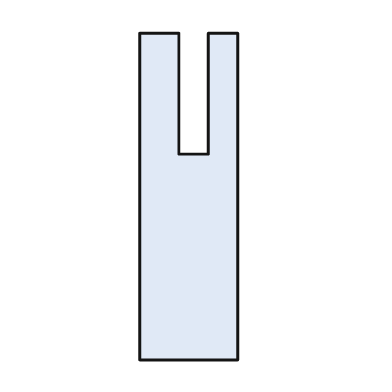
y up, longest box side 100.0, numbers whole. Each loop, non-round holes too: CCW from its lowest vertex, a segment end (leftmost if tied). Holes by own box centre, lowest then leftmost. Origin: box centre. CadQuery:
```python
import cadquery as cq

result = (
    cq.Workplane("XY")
    .moveTo(-15.0, -50.0)
    .lineTo(15.0, -50.0)
    .lineTo(15.0, 50.0)
    .lineTo(6.0, 50.0)
    .lineTo(6.0, 13.0)
    .lineTo(-3.0, 13.0)
    .lineTo(-3.0, 50.0)
    .lineTo(-15.0, 50.0)
    .close()
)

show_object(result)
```